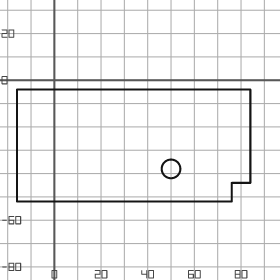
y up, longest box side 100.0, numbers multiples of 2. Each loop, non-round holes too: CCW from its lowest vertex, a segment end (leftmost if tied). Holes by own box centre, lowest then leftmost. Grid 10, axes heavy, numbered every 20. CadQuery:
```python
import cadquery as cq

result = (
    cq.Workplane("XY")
    .moveTo(-16.0, -52.0)
    .lineTo(76.0, -52.0)
    .lineTo(76.0, -44.0)
    .lineTo(84.0, -44.0)
    .lineTo(84.0, -4.0)
    .lineTo(-16.0, -4.0)
    .close()
    .moveTo(50.0, -38.0)
    .circle(4.0)
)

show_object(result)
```